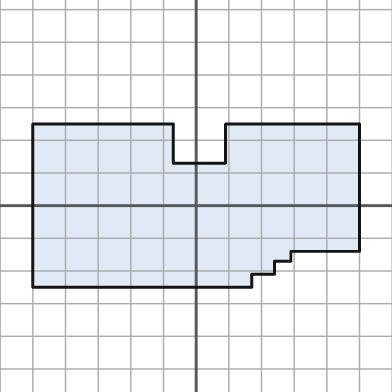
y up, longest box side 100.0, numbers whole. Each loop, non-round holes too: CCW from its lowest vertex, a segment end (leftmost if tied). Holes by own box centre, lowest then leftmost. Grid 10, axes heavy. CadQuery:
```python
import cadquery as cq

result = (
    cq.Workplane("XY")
    .moveTo(-50.0, -25.0)
    .lineTo(17.0, -25.0)
    .lineTo(17.0, -21.0)
    .lineTo(24.0, -21.0)
    .lineTo(24.0, -17.0)
    .lineTo(29.0, -17.0)
    .lineTo(29.0, -14.0)
    .lineTo(50.0, -14.0)
    .lineTo(50.0, 25.0)
    .lineTo(9.0, 25.0)
    .lineTo(9.0, 13.0)
    .lineTo(-7.0, 13.0)
    .lineTo(-7.0, 25.0)
    .lineTo(-50.0, 25.0)
    .close()
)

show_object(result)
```